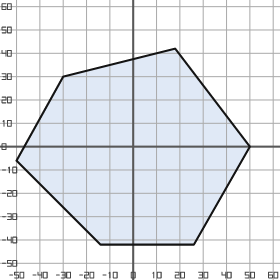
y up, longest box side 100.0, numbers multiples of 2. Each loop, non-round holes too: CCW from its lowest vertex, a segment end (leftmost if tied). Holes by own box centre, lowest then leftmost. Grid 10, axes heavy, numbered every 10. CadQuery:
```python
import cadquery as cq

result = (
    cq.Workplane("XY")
    .moveTo(-14.0, -42.0)
    .lineTo(26.0, -42.0)
    .lineTo(50.0, 0.0)
    .lineTo(18.0, 42.0)
    .lineTo(-30.0, 30.0)
    .lineTo(-50.0, -6.0)
    .close()
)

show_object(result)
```